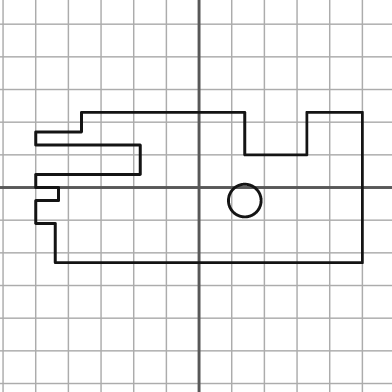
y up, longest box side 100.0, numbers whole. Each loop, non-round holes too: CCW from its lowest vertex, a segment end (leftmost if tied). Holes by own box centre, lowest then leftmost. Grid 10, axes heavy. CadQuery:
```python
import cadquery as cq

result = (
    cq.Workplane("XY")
    .moveTo(-44.0, -23.0)
    .lineTo(50.0, -23.0)
    .lineTo(50.0, 23.0)
    .lineTo(33.0, 23.0)
    .lineTo(33.0, 10.0)
    .lineTo(14.0, 10.0)
    .lineTo(14.0, 23.0)
    .lineTo(-36.0, 23.0)
    .lineTo(-36.0, 17.0)
    .lineTo(-50.0, 17.0)
    .lineTo(-50.0, 13.0)
    .lineTo(-18.0, 13.0)
    .lineTo(-18.0, 4.0)
    .lineTo(-50.0, 4.0)
    .lineTo(-50.0, 0.0)
    .lineTo(-43.0, 0.0)
    .lineTo(-43.0, -4.0)
    .lineTo(-50.0, -4.0)
    .lineTo(-50.0, -11.0)
    .lineTo(-44.0, -11.0)
    .close()
    .moveTo(14.0, -4.0)
    .circle(5.0)
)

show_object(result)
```